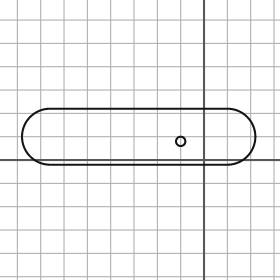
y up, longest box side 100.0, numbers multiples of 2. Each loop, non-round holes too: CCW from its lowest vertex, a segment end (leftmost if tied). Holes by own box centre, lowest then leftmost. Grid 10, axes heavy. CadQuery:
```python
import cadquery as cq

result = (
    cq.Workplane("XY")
    .moveTo(-66.0, -2.0)
    .lineTo(10.0, -2.0)
    .threePointArc((22.0, 10.0), (10.0, 22.0))
    .lineTo(-66.0, 22.0)
    .threePointArc((-78.0, 10.0), (-66.0, -2.0))
    .close()
    .moveTo(-10.0, 8.0)
    .circle(2.0)
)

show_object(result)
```